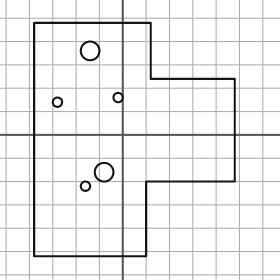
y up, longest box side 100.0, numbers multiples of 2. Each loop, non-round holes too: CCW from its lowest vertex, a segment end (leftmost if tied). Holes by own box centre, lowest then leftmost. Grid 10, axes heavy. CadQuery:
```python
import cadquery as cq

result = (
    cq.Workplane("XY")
    .moveTo(-38.0, -52.0)
    .lineTo(10.0, -52.0)
    .lineTo(10.0, -20.0)
    .lineTo(48.0, -20.0)
    .lineTo(48.0, 24.0)
    .lineTo(12.0, 24.0)
    .lineTo(12.0, 48.0)
    .lineTo(-38.0, 48.0)
    .close()
    .moveTo(-16.0, -22.0)
    .circle(2.0)
    .moveTo(-8.0, -16.0)
    .circle(4.0)
    .moveTo(-28.0, 14.0)
    .circle(2.0)
    .moveTo(-2.0, 16.0)
    .circle(2.0)
    .moveTo(-14.0, 36.0)
    .circle(4.0)
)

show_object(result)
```